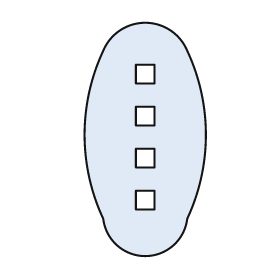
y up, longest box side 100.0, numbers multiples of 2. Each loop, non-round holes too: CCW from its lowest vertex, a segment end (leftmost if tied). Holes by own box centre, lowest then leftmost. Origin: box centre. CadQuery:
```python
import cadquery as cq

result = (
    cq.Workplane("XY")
    .moveTo(-18.0, -34.0)
    .threePointArc((0.0, -50.0), (18.0, -34.0))
    .threePointArc((26.0, 2.0), (18.0, 38.0))
    .threePointArc((0.0, 50.0), (-18.0, 38.0))
    .threePointArc((-26.0, 2.0), (-18.0, -34.0))
    .close()
    .moveTo(-4.0, -30.0)
    .lineTo(4.0, -30.0)
    .lineTo(4.0, -22.0)
    .lineTo(-4.0, -22.0)
    .close()
    .moveTo(-4.0, -12.0)
    .lineTo(4.0, -12.0)
    .lineTo(4.0, -4.0)
    .lineTo(-4.0, -4.0)
    .close()
    .moveTo(-4.0, 6.0)
    .lineTo(4.0, 6.0)
    .lineTo(4.0, 14.0)
    .lineTo(-4.0, 14.0)
    .close()
    .moveTo(-4.0, 24.0)
    .lineTo(4.0, 24.0)
    .lineTo(4.0, 32.0)
    .lineTo(-4.0, 32.0)
    .close()
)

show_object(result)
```